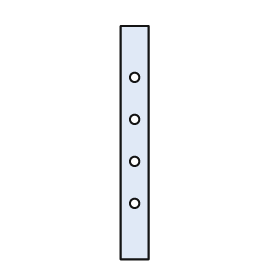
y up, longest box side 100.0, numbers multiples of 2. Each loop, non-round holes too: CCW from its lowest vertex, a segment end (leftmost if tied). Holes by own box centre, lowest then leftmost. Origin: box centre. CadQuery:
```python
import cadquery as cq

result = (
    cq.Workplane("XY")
    .moveTo(-6.0, -50.0)
    .lineTo(6.0, -50.0)
    .lineTo(6.0, 50.0)
    .lineTo(-6.0, 50.0)
    .close()
    .moveTo(0.0, -26.0)
    .circle(2.0)
    .moveTo(0.0, -8.0)
    .circle(2.0)
    .moveTo(0.0, 10.0)
    .circle(2.0)
    .moveTo(0.0, 28.0)
    .circle(2.0)
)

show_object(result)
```